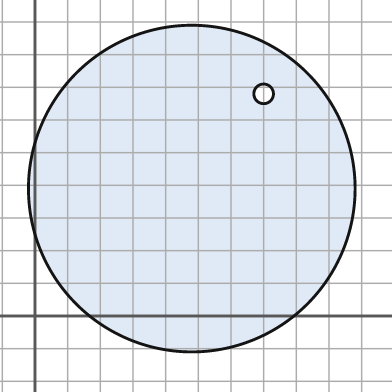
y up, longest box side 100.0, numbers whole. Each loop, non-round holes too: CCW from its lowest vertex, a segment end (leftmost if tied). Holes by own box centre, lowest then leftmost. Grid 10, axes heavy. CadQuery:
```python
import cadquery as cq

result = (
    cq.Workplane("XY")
    .moveTo(48.0, 39.0)
    .circle(50.0)
    .moveTo(70.0, 68.0)
    .circle(3.0)
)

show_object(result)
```